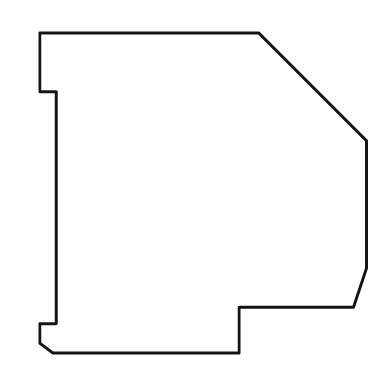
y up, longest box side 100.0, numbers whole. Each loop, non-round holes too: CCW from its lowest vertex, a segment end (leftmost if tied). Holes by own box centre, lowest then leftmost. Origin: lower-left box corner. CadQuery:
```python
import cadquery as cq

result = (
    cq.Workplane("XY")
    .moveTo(4.0, 0.0)
    .lineTo(61.0, 0.0)
    .lineTo(61.0, 14.0)
    .lineTo(96.0, 14.0)
    .lineTo(100.0, 26.0)
    .lineTo(100.0, 65.0)
    .lineTo(67.0, 98.0)
    .lineTo(0.0, 98.0)
    .lineTo(0.0, 80.0)
    .lineTo(5.0, 80.0)
    .lineTo(5.0, 9.0)
    .lineTo(0.0, 9.0)
    .lineTo(0.0, 3.0)
    .close()
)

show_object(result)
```